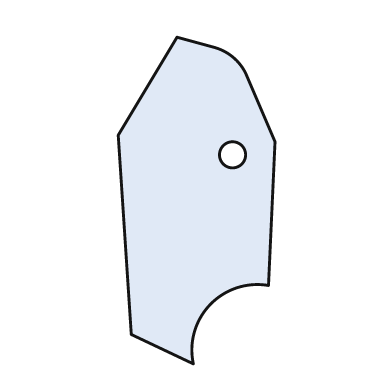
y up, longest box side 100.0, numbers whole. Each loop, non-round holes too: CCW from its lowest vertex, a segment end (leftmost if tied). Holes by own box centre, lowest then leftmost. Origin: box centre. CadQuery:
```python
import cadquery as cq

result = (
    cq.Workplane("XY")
    .moveTo(-1.0, -50.0)
    .threePointArc((4.0, -32.0), (22.0, -26.0))
    .lineTo(24.0, 18.0)
    .lineTo(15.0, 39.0)
    .threePointArc((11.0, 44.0), (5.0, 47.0))
    .lineTo(-6.0, 50.0)
    .lineTo(-24.0, 20.0)
    .lineTo(-20.0, -41.0)
    .close()
    .moveTo(11.0, 14.0)
    .circle(4.0)
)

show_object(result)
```